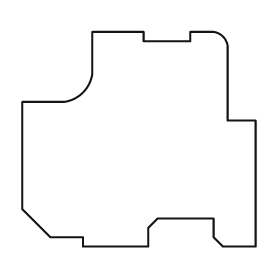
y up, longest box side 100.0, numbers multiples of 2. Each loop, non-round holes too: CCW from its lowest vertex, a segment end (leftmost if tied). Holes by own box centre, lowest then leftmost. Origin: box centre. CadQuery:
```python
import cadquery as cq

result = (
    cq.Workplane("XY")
    .moveTo(-24.0, -46.0)
    .lineTo(4.0, -46.0)
    .lineTo(4.0, -38.0)
    .lineTo(8.0, -34.0)
    .lineTo(32.0, -34.0)
    .lineTo(32.0, -42.0)
    .lineTo(36.0, -46.0)
    .lineTo(50.0, -46.0)
    .lineTo(50.0, 8.0)
    .lineTo(38.0, 8.0)
    .lineTo(38.0, 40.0)
    .threePointArc((36.0, 44.0), (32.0, 46.0))
    .lineTo(22.0, 46.0)
    .lineTo(22.0, 42.0)
    .lineTo(2.0, 42.0)
    .lineTo(2.0, 46.0)
    .lineTo(-20.0, 46.0)
    .lineTo(-20.0, 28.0)
    .threePointArc((-24.0, 20.0), (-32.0, 16.0))
    .lineTo(-50.0, 16.0)
    .lineTo(-50.0, -30.0)
    .lineTo(-38.0, -42.0)
    .lineTo(-24.0, -42.0)
    .close()
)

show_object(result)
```